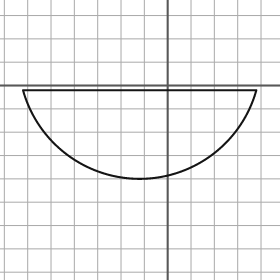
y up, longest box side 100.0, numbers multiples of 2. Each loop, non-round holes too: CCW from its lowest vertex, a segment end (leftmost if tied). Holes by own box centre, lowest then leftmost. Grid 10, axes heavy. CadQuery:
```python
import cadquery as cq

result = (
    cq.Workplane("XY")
    .moveTo(-62.0, -2.0)
    .threePointArc((-12.0, -40.0), (38.0, -2.0))
    .close()
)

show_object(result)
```